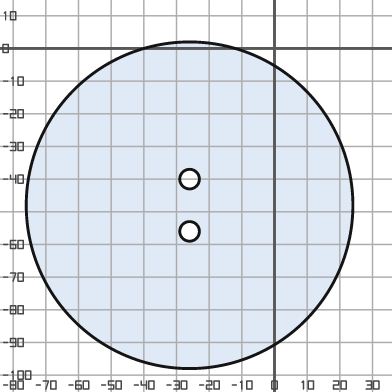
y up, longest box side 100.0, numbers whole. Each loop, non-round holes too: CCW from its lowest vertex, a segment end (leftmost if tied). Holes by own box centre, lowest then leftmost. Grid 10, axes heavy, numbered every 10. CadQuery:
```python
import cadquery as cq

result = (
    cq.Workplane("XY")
    .moveTo(-26.0, -48.0)
    .circle(50.0)
    .moveTo(-26.0, -56.0)
    .circle(3.0)
    .moveTo(-26.0, -40.0)
    .circle(3.0)
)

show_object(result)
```